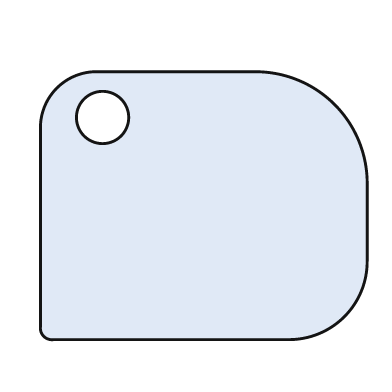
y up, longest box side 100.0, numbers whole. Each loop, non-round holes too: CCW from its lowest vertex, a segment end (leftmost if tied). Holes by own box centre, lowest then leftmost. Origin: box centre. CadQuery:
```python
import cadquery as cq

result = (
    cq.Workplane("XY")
    .moveTo(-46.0, -41.0)
    .lineTo(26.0, -41.0)
    .threePointArc((43.0, -34.0), (50.0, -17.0))
    .lineTo(50.0, 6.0)
    .threePointArc((40.0, 31.0), (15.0, 41.0))
    .lineTo(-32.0, 41.0)
    .threePointArc((-45.0, 36.0), (-50.0, 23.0))
    .lineTo(-50.0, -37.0)
    .threePointArc((-49.0, -40.0), (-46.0, -41.0))
    .close()
    .moveTo(-31.0, 27.0)
    .circle(8.0)
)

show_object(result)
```